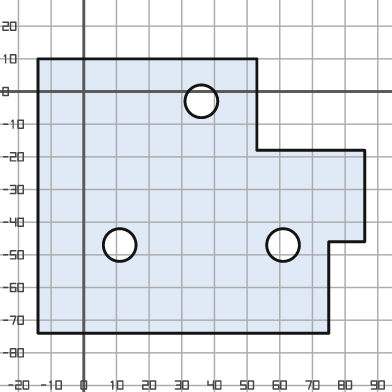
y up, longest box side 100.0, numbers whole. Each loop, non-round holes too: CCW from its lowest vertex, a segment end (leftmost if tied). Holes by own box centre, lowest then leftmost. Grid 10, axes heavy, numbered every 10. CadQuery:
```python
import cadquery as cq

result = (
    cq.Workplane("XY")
    .moveTo(-14.0, -74.0)
    .lineTo(75.0, -74.0)
    .lineTo(75.0, -46.0)
    .lineTo(86.0, -46.0)
    .lineTo(86.0, -18.0)
    .lineTo(53.0, -18.0)
    .lineTo(53.0, 10.0)
    .lineTo(-14.0, 10.0)
    .close()
    .moveTo(11.0, -47.0)
    .circle(5.0)
    .moveTo(61.0, -47.0)
    .circle(5.0)
    .moveTo(36.0, -3.0)
    .circle(5.0)
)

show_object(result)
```